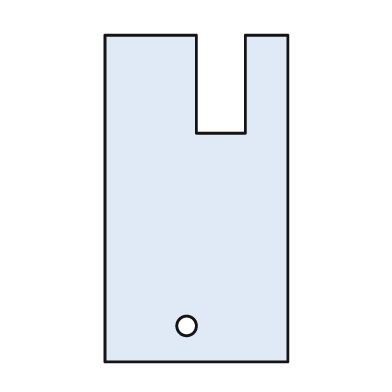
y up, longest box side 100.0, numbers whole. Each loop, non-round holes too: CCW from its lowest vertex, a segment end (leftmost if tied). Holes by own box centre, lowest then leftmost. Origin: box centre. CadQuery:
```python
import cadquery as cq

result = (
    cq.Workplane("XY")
    .moveTo(-28.0, -50.0)
    .lineTo(28.0, -50.0)
    .lineTo(28.0, 50.0)
    .lineTo(15.0, 50.0)
    .lineTo(15.0, 20.0)
    .lineTo(0.0, 20.0)
    .lineTo(0.0, 50.0)
    .lineTo(-28.0, 50.0)
    .close()
    .moveTo(-3.0, -39.0)
    .circle(3.0)
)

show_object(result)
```